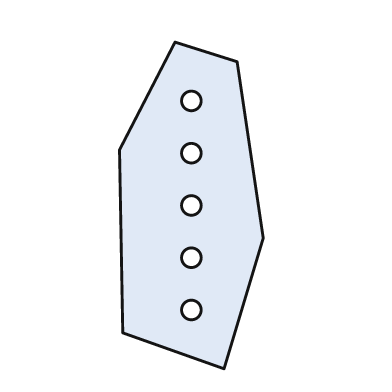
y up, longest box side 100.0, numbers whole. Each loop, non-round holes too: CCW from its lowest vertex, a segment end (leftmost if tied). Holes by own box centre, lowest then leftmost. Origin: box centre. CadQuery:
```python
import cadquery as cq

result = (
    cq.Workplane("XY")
    .moveTo(10.0, -50.0)
    .lineTo(22.0, -10.0)
    .lineTo(14.0, 44.0)
    .lineTo(-5.0, 50.0)
    .lineTo(-22.0, 17.0)
    .lineTo(-21.0, -39.0)
    .close()
    .moveTo(0.0, -32.0)
    .circle(3.0)
    .moveTo(0.0, -16.0)
    .circle(3.0)
    .moveTo(0.0, 0.0)
    .circle(3.0)
    .moveTo(0.0, 16.0)
    .circle(3.0)
    .moveTo(0.0, 32.0)
    .circle(3.0)
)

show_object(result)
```